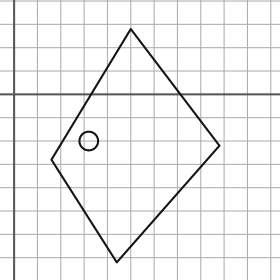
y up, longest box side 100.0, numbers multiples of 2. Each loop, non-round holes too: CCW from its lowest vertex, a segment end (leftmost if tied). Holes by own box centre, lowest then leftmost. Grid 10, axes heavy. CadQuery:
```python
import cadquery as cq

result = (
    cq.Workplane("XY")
    .moveTo(44.0, -72.0)
    .lineTo(88.0, -22.0)
    .lineTo(50.0, 28.0)
    .lineTo(16.0, -28.0)
    .close()
    .moveTo(32.0, -20.0)
    .circle(4.0)
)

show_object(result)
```